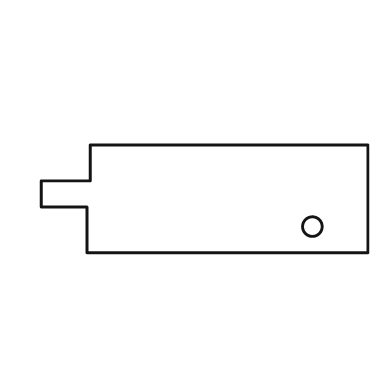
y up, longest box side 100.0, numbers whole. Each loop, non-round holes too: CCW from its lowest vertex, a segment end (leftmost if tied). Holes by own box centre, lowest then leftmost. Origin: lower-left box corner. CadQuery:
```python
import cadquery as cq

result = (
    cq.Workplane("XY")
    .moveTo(14.0, 0.0)
    .lineTo(100.0, 0.0)
    .lineTo(100.0, 33.0)
    .lineTo(15.0, 33.0)
    .lineTo(15.0, 22.0)
    .lineTo(0.0, 22.0)
    .lineTo(0.0, 14.0)
    .lineTo(14.0, 14.0)
    .close()
    .moveTo(83.0, 8.0)
    .circle(3.0)
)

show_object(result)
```